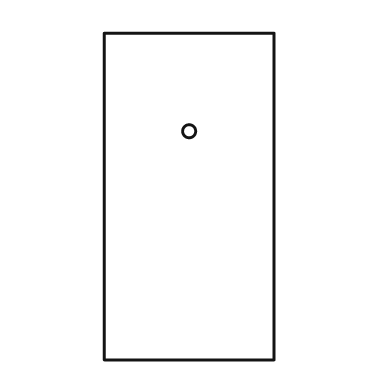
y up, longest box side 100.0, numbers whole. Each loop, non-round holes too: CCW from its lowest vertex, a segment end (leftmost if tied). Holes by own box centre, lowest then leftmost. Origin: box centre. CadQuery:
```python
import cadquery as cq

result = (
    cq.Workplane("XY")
    .moveTo(-26.0, -50.0)
    .lineTo(26.0, -50.0)
    .lineTo(26.0, 50.0)
    .lineTo(-26.0, 50.0)
    .close()
    .moveTo(0.0, 20.0)
    .circle(2.0)
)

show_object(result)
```